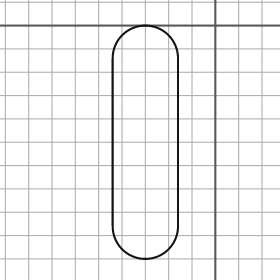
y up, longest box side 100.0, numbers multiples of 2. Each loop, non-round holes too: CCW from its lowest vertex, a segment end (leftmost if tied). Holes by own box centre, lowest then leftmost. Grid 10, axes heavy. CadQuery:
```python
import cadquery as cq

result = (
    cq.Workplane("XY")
    .moveTo(-44.0, -86.0)
    .threePointArc((-30.0, -100.0), (-16.0, -86.0))
    .lineTo(-16.0, -14.0)
    .threePointArc((-30.0, 0.0), (-44.0, -14.0))
    .close()
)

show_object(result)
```